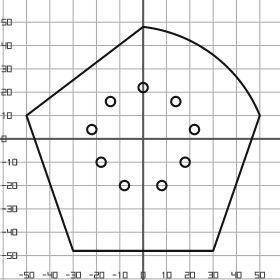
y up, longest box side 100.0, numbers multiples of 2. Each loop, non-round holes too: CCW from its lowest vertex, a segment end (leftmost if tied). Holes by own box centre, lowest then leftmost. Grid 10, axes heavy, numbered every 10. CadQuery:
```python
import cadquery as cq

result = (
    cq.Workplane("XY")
    .moveTo(-30.0, -48.0)
    .lineTo(30.0, -48.0)
    .lineTo(50.0, 10.0)
    .threePointArc((30.0, 36.0), (0.0, 48.0))
    .lineTo(-50.0, 10.0)
    .close()
    .moveTo(-8.0, -20.0)
    .circle(2.0)
    .moveTo(8.0, -20.0)
    .circle(2.0)
    .moveTo(-18.0, -10.0)
    .circle(2.0)
    .moveTo(18.0, -10.0)
    .circle(2.0)
    .moveTo(-22.0, 4.0)
    .circle(2.0)
    .moveTo(22.0, 4.0)
    .circle(2.0)
    .moveTo(-14.0, 16.0)
    .circle(2.0)
    .moveTo(14.0, 16.0)
    .circle(2.0)
    .moveTo(0.0, 22.0)
    .circle(2.0)
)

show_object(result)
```